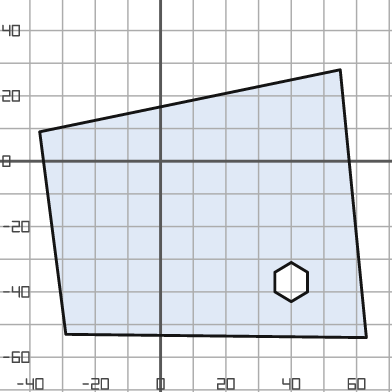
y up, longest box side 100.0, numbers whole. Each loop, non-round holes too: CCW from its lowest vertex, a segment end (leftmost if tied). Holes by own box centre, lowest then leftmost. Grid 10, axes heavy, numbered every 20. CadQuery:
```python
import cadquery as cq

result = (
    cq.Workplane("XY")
    .moveTo(63.0, -54.0)
    .lineTo(55.0, 28.0)
    .lineTo(-37.0, 9.0)
    .lineTo(-29.0, -53.0)
    .close()
    .moveTo(40.0, -43.0)
    .lineTo(45.0, -40.0)
    .lineTo(45.0, -34.0)
    .lineTo(40.0, -31.0)
    .lineTo(35.0, -34.0)
    .lineTo(35.0, -40.0)
    .close()
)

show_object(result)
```